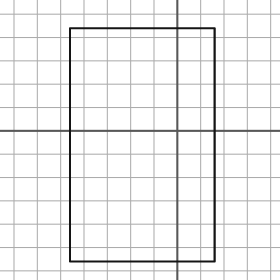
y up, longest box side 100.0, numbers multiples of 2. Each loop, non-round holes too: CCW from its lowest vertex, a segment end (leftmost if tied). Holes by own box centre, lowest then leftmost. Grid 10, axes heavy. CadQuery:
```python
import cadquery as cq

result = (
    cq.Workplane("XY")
    .moveTo(-46.0, -56.0)
    .lineTo(16.0, -56.0)
    .lineTo(16.0, 44.0)
    .lineTo(-46.0, 44.0)
    .close()
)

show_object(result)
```